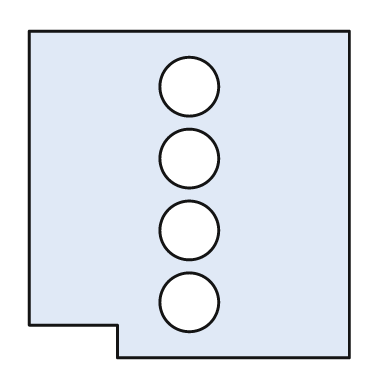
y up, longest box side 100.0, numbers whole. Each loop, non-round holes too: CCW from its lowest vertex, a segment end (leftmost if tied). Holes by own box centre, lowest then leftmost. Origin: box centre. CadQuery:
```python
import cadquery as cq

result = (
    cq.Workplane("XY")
    .moveTo(-22.0, -50.0)
    .lineTo(49.0, -50.0)
    .lineTo(49.0, 50.0)
    .lineTo(-49.0, 50.0)
    .lineTo(-49.0, -40.0)
    .lineTo(-22.0, -40.0)
    .close()
    .moveTo(0.0, -33.0)
    .circle(9.0)
    .moveTo(0.0, -11.0)
    .circle(9.0)
    .moveTo(0.0, 11.0)
    .circle(9.0)
    .moveTo(0.0, 33.0)
    .circle(9.0)
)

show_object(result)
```